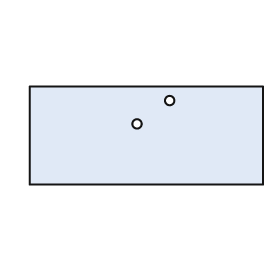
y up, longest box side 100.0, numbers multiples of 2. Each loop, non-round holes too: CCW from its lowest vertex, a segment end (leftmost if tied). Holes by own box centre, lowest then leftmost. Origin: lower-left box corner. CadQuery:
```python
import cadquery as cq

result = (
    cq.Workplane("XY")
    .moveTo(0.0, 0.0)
    .lineTo(100.0, 0.0)
    .lineTo(100.0, 42.0)
    .lineTo(0.0, 42.0)
    .close()
    .moveTo(46.0, 26.0)
    .circle(2.0)
    .moveTo(60.0, 36.0)
    .circle(2.0)
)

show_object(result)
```